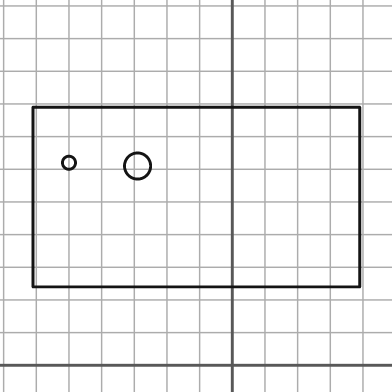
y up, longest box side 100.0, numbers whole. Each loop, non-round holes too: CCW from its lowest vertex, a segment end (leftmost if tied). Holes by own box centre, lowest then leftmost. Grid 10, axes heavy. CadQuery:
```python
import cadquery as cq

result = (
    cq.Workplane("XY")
    .moveTo(-61.0, 24.0)
    .lineTo(39.0, 24.0)
    .lineTo(39.0, 79.0)
    .lineTo(-61.0, 79.0)
    .close()
    .moveTo(-29.0, 61.0)
    .circle(4.0)
    .moveTo(-50.0, 62.0)
    .circle(2.0)
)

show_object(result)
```